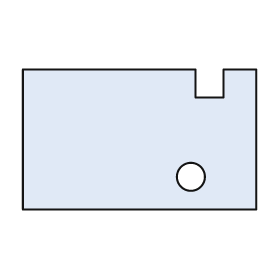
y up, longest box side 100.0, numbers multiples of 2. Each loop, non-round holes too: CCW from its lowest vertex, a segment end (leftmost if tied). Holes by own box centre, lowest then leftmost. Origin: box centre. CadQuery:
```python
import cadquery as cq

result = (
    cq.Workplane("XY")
    .moveTo(-50.0, -30.0)
    .lineTo(50.0, -30.0)
    .lineTo(50.0, 30.0)
    .lineTo(36.0, 30.0)
    .lineTo(36.0, 18.0)
    .lineTo(24.0, 18.0)
    .lineTo(24.0, 30.0)
    .lineTo(-50.0, 30.0)
    .close()
    .moveTo(22.0, -16.0)
    .circle(6.0)
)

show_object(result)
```